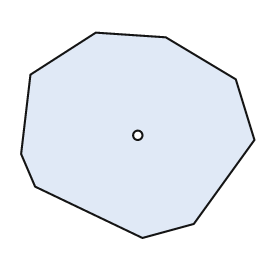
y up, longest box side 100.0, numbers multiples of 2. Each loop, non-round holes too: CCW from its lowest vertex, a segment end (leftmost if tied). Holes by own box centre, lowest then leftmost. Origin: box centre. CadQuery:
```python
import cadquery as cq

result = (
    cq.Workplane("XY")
    .moveTo(2.0, -44.0)
    .lineTo(24.0, -38.0)
    .lineTo(50.0, -2.0)
    .lineTo(42.0, 24.0)
    .lineTo(12.0, 42.0)
    .lineTo(-18.0, 44.0)
    .lineTo(-46.0, 26.0)
    .lineTo(-50.0, -8.0)
    .lineTo(-44.0, -22.0)
    .close()
    .moveTo(0.0, 0.0)
    .circle(2.0)
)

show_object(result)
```